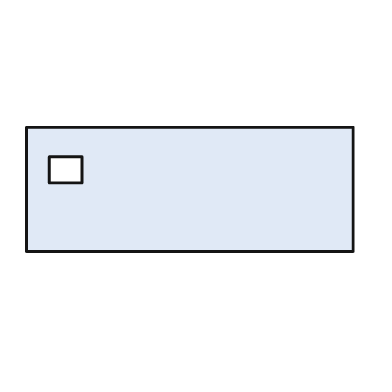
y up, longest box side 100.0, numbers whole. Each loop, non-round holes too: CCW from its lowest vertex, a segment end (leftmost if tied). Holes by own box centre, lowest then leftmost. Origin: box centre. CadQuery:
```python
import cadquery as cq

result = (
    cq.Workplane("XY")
    .moveTo(-50.0, -19.0)
    .lineTo(50.0, -19.0)
    .lineTo(50.0, 19.0)
    .lineTo(-50.0, 19.0)
    .close()
    .moveTo(-43.0, 2.0)
    .lineTo(-33.0, 2.0)
    .lineTo(-33.0, 10.0)
    .lineTo(-43.0, 10.0)
    .close()
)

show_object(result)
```